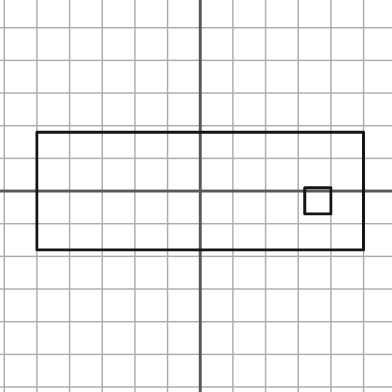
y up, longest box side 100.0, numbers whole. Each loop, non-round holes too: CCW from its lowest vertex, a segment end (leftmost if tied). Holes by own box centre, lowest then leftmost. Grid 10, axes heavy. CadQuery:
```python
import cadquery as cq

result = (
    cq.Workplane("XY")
    .moveTo(-50.0, -18.0)
    .lineTo(50.0, -18.0)
    .lineTo(50.0, 18.0)
    .lineTo(-50.0, 18.0)
    .close()
    .moveTo(32.0, -7.0)
    .lineTo(40.0, -7.0)
    .lineTo(40.0, 1.0)
    .lineTo(32.0, 1.0)
    .close()
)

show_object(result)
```